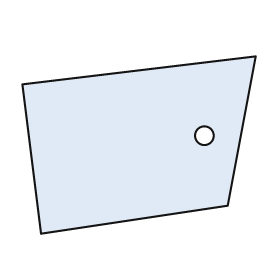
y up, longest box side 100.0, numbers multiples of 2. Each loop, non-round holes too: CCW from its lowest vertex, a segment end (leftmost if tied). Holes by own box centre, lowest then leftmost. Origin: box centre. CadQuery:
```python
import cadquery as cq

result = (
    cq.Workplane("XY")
    .moveTo(-42.0, -38.0)
    .lineTo(38.0, -26.0)
    .lineTo(50.0, 38.0)
    .lineTo(-50.0, 26.0)
    .close()
    .moveTo(28.0, 4.0)
    .circle(4.0)
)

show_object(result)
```